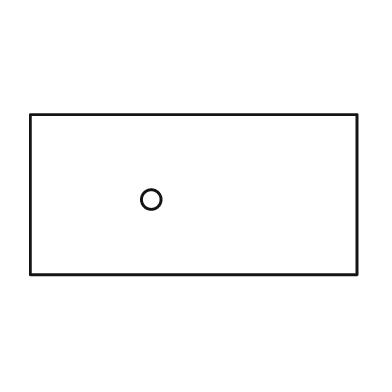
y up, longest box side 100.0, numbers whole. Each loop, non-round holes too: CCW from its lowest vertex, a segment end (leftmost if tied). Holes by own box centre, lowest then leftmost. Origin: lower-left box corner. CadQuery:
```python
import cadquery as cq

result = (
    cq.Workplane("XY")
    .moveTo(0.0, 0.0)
    .lineTo(100.0, 0.0)
    .lineTo(100.0, 49.0)
    .lineTo(0.0, 49.0)
    .close()
    .moveTo(37.0, 23.0)
    .circle(3.0)
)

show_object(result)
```